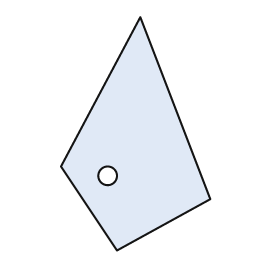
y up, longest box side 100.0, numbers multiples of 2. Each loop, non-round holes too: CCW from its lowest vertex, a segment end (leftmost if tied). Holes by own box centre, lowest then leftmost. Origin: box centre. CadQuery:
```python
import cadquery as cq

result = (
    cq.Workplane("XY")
    .moveTo(-8.0, -50.0)
    .lineTo(32.0, -28.0)
    .lineTo(2.0, 50.0)
    .lineTo(-32.0, -14.0)
    .close()
    .moveTo(-12.0, -18.0)
    .circle(4.0)
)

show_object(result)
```